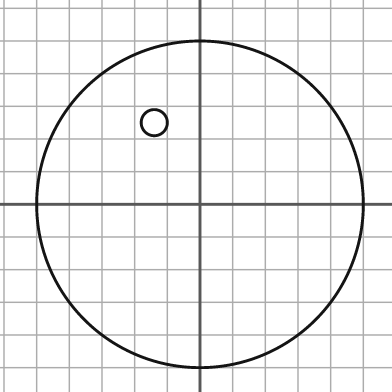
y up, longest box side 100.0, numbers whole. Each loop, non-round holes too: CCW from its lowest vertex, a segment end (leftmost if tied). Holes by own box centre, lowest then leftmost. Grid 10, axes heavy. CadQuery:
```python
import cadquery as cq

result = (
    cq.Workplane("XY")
    .moveTo(0.0, 0.0)
    .circle(50.0)
    .moveTo(-14.0, 25.0)
    .circle(4.0)
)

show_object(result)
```